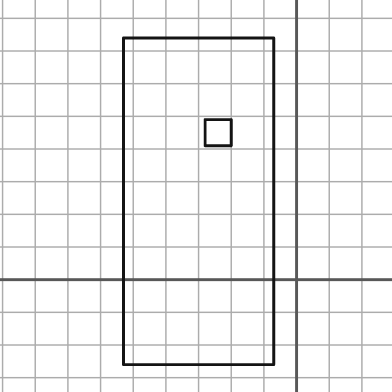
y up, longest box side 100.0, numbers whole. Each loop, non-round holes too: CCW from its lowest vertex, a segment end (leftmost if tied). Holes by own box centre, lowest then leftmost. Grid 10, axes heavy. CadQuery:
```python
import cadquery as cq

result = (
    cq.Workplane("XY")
    .moveTo(-53.0, -26.0)
    .lineTo(-7.0, -26.0)
    .lineTo(-7.0, 74.0)
    .lineTo(-53.0, 74.0)
    .close()
    .moveTo(-28.0, 41.0)
    .lineTo(-20.0, 41.0)
    .lineTo(-20.0, 49.0)
    .lineTo(-28.0, 49.0)
    .close()
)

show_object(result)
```